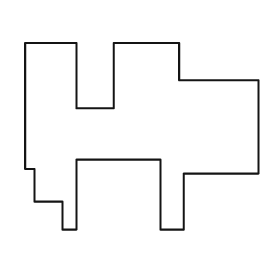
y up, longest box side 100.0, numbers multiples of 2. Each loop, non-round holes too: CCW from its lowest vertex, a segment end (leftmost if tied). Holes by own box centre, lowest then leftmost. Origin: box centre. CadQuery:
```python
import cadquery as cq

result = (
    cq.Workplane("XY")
    .moveTo(-34.0, -40.0)
    .lineTo(-28.0, -40.0)
    .lineTo(-28.0, -10.0)
    .lineTo(8.0, -10.0)
    .lineTo(8.0, -40.0)
    .lineTo(18.0, -40.0)
    .lineTo(18.0, -16.0)
    .lineTo(50.0, -16.0)
    .lineTo(50.0, 24.0)
    .lineTo(16.0, 24.0)
    .lineTo(16.0, 40.0)
    .lineTo(-12.0, 40.0)
    .lineTo(-12.0, 12.0)
    .lineTo(-28.0, 12.0)
    .lineTo(-28.0, 40.0)
    .lineTo(-50.0, 40.0)
    .lineTo(-50.0, -14.0)
    .lineTo(-46.0, -14.0)
    .lineTo(-46.0, -28.0)
    .lineTo(-34.0, -28.0)
    .close()
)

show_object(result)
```